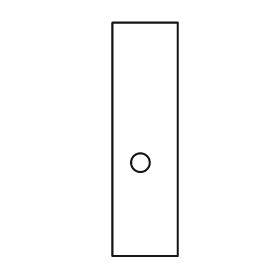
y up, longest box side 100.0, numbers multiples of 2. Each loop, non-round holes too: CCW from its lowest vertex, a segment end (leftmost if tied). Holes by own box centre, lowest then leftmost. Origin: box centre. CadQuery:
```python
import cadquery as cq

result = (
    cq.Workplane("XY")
    .moveTo(-14.0, -50.0)
    .lineTo(14.0, -50.0)
    .lineTo(14.0, 50.0)
    .lineTo(-14.0, 50.0)
    .close()
    .moveTo(-2.0, -10.0)
    .circle(4.0)
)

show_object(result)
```